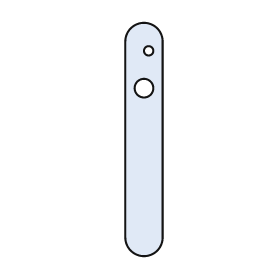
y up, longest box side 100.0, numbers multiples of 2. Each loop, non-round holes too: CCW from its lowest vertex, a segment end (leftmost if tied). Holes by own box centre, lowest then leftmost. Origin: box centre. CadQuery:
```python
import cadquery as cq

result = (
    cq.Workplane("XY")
    .moveTo(-8.0, -42.0)
    .threePointArc((0.0, -50.0), (8.0, -42.0))
    .lineTo(8.0, 42.0)
    .threePointArc((0.0, 50.0), (-8.0, 42.0))
    .close()
    .moveTo(0.0, 22.0)
    .circle(4.0)
    .moveTo(2.0, 38.0)
    .circle(2.0)
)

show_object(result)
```